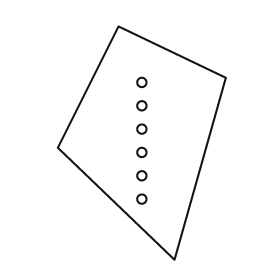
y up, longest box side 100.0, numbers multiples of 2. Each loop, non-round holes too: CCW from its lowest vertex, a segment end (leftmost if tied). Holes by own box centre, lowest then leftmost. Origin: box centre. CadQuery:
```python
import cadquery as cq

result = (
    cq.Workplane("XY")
    .moveTo(14.0, -50.0)
    .lineTo(36.0, 28.0)
    .lineTo(-10.0, 50.0)
    .lineTo(-36.0, -2.0)
    .close()
    .moveTo(0.0, -24.0)
    .circle(2.0)
    .moveTo(0.0, -14.0)
    .circle(2.0)
    .moveTo(0.0, -4.0)
    .circle(2.0)
    .moveTo(0.0, 6.0)
    .circle(2.0)
    .moveTo(0.0, 16.0)
    .circle(2.0)
    .moveTo(0.0, 26.0)
    .circle(2.0)
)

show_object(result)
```